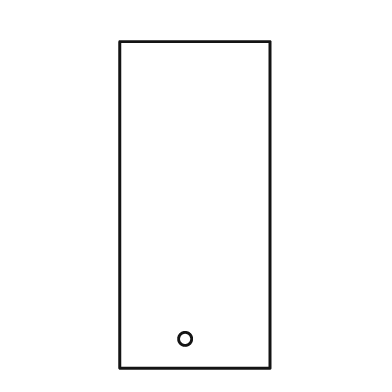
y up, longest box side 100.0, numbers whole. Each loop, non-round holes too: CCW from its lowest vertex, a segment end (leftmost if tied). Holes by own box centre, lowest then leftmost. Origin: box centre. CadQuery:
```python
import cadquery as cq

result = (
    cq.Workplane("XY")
    .moveTo(-23.0, -50.0)
    .lineTo(23.0, -50.0)
    .lineTo(23.0, 50.0)
    .lineTo(-23.0, 50.0)
    .close()
    .moveTo(-3.0, -41.0)
    .circle(2.0)
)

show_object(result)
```